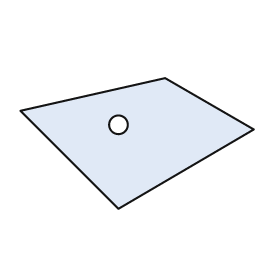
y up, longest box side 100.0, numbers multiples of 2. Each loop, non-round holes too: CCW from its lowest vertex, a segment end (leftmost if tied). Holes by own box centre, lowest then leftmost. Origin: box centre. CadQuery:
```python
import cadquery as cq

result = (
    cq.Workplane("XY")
    .moveTo(-8.0, -28.0)
    .lineTo(50.0, 6.0)
    .lineTo(12.0, 28.0)
    .lineTo(-50.0, 14.0)
    .close()
    .moveTo(-8.0, 8.0)
    .circle(4.0)
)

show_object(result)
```